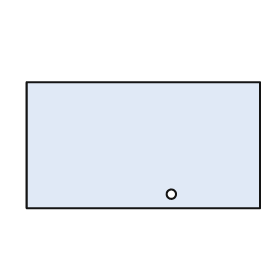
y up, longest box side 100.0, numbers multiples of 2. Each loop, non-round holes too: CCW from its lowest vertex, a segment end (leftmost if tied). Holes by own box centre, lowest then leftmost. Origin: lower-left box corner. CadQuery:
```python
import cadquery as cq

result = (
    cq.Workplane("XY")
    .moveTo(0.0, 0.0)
    .lineTo(100.0, 0.0)
    .lineTo(100.0, 54.0)
    .lineTo(0.0, 54.0)
    .close()
    .moveTo(62.0, 6.0)
    .circle(2.0)
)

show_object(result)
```